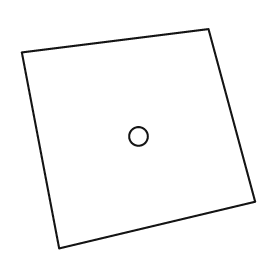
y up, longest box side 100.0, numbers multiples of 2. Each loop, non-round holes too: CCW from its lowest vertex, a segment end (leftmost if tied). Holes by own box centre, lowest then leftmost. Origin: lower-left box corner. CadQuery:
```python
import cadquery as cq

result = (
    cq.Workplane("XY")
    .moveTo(16.0, 0.0)
    .lineTo(100.0, 20.0)
    .lineTo(80.0, 94.0)
    .lineTo(0.0, 84.0)
    .close()
    .moveTo(50.0, 48.0)
    .circle(4.0)
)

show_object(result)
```